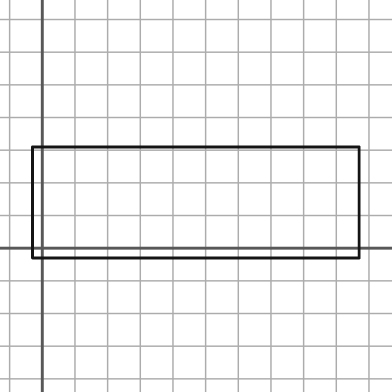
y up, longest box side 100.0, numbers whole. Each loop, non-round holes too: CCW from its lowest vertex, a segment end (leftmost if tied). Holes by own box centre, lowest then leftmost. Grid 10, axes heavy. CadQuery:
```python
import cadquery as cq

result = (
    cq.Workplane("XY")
    .moveTo(-3.0, -3.0)
    .lineTo(97.0, -3.0)
    .lineTo(97.0, 31.0)
    .lineTo(-3.0, 31.0)
    .close()
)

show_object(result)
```